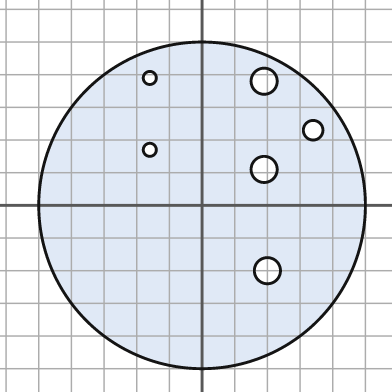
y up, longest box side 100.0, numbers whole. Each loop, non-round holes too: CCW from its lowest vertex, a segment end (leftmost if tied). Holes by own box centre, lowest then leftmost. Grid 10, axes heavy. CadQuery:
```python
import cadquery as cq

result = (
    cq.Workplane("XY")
    .moveTo(0.0, 0.0)
    .circle(50.0)
    .moveTo(20.0, -20.0)
    .circle(4.0)
    .moveTo(19.0, 11.0)
    .circle(4.0)
    .moveTo(-16.0, 17.0)
    .circle(2.0)
    .moveTo(34.0, 23.0)
    .circle(3.0)
    .moveTo(19.0, 38.0)
    .circle(4.0)
    .moveTo(-16.0, 39.0)
    .circle(2.0)
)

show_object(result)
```